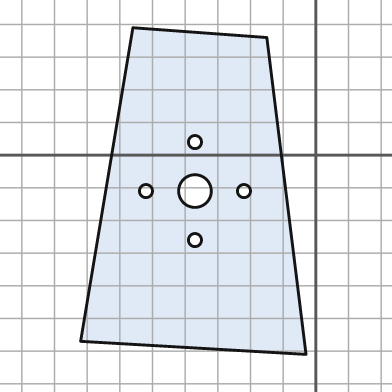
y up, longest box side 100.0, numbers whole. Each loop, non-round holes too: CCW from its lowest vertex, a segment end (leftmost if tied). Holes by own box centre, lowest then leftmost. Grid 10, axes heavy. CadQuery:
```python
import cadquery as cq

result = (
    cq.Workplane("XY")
    .moveTo(-3.0, -61.0)
    .lineTo(-15.0, 36.0)
    .lineTo(-56.0, 39.0)
    .lineTo(-72.0, -57.0)
    .close()
    .moveTo(-37.0, -26.0)
    .circle(2.0)
    .moveTo(-52.0, -11.0)
    .circle(2.0)
    .moveTo(-37.0, -11.0)
    .circle(5.0)
    .moveTo(-22.0, -11.0)
    .circle(2.0)
    .moveTo(-37.0, 4.0)
    .circle(2.0)
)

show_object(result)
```